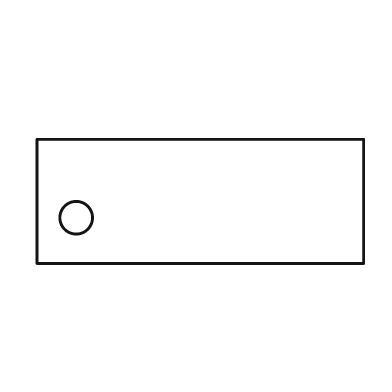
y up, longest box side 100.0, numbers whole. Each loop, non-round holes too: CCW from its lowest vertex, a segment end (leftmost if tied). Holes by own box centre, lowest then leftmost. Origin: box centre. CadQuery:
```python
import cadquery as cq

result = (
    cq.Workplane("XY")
    .moveTo(-50.0, -19.0)
    .lineTo(50.0, -19.0)
    .lineTo(50.0, 19.0)
    .lineTo(-50.0, 19.0)
    .close()
    .moveTo(-38.0, -5.0)
    .circle(5.0)
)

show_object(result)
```